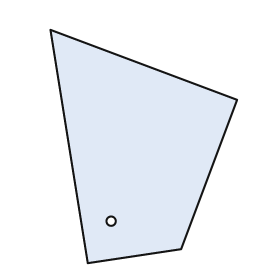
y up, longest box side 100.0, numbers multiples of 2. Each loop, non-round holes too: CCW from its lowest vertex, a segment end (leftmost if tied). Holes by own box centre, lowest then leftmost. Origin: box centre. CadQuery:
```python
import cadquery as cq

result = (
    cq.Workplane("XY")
    .moveTo(-24.0, -50.0)
    .lineTo(16.0, -44.0)
    .lineTo(40.0, 20.0)
    .lineTo(-40.0, 50.0)
    .close()
    .moveTo(-14.0, -32.0)
    .circle(2.0)
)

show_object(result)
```